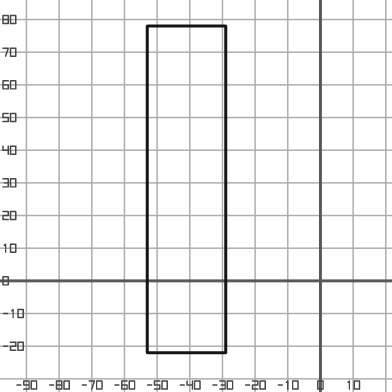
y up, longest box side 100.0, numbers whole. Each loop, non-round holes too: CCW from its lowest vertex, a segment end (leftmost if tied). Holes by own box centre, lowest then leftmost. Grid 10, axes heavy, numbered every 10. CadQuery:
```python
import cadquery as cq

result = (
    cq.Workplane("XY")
    .moveTo(-53.0, -22.0)
    .lineTo(-29.0, -22.0)
    .lineTo(-29.0, 78.0)
    .lineTo(-53.0, 78.0)
    .close()
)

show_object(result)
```